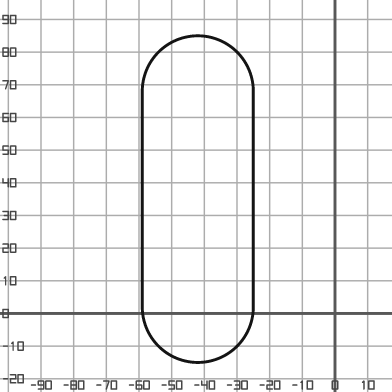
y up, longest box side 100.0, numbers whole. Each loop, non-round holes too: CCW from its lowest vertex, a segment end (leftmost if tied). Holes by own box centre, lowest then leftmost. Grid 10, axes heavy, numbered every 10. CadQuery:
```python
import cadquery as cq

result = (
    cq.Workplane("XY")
    .moveTo(-59.0, 2.0)
    .threePointArc((-42.0, -15.0), (-25.0, 2.0))
    .lineTo(-25.0, 68.0)
    .threePointArc((-42.0, 85.0), (-59.0, 68.0))
    .close()
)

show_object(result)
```